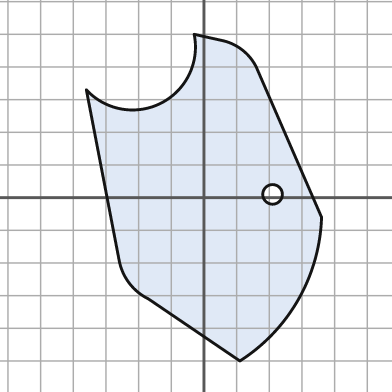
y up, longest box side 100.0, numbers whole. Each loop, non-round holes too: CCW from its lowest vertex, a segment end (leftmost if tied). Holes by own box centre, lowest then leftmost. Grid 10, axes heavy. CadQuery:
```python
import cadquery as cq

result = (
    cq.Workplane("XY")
    .moveTo(11.0, -50.0)
    .threePointArc((29.0, -31.0), (36.0, -6.0))
    .lineTo(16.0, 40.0)
    .threePointArc((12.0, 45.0), (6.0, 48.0))
    .lineTo(-3.0, 50.0)
    .threePointArc((-13.0, 29.0), (-36.0, 33.0))
    .lineTo(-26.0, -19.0)
    .threePointArc((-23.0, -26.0), (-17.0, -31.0))
    .close()
    .moveTo(21.0, 1.0)
    .circle(3.0)
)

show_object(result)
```